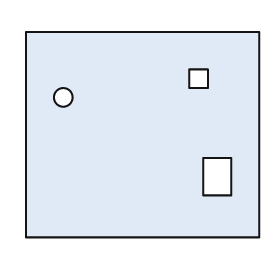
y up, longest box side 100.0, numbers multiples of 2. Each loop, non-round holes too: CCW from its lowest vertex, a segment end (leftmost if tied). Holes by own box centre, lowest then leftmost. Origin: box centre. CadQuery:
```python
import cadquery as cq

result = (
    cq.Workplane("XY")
    .moveTo(-50.0, -44.0)
    .lineTo(50.0, -44.0)
    .lineTo(50.0, 44.0)
    .lineTo(-50.0, 44.0)
    .close()
    .moveTo(26.0, -26.0)
    .lineTo(38.0, -26.0)
    .lineTo(38.0, -10.0)
    .lineTo(26.0, -10.0)
    .close()
    .moveTo(-34.0, 16.0)
    .circle(4.0)
    .moveTo(20.0, 20.0)
    .lineTo(28.0, 20.0)
    .lineTo(28.0, 28.0)
    .lineTo(20.0, 28.0)
    .close()
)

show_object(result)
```